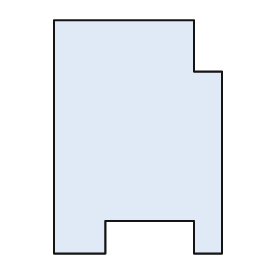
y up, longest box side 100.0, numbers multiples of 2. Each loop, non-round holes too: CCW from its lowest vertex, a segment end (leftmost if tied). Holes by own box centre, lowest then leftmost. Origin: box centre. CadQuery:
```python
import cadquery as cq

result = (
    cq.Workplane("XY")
    .moveTo(-36.0, -50.0)
    .lineTo(-14.0, -50.0)
    .lineTo(-14.0, -36.0)
    .lineTo(24.0, -36.0)
    .lineTo(24.0, -50.0)
    .lineTo(36.0, -50.0)
    .lineTo(36.0, 28.0)
    .lineTo(24.0, 28.0)
    .lineTo(24.0, 50.0)
    .lineTo(-36.0, 50.0)
    .close()
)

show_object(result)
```